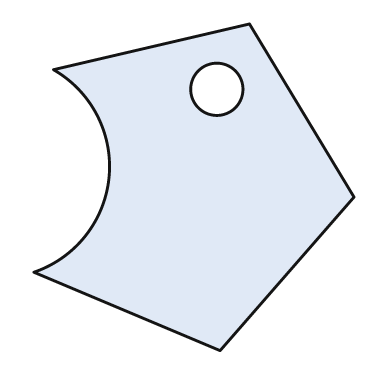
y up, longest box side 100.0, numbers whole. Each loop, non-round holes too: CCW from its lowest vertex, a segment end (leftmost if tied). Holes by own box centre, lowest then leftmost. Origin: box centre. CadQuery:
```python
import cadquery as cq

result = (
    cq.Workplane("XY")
    .moveTo(8.0, -50.0)
    .lineTo(49.0, -3.0)
    .lineTo(17.0, 50.0)
    .lineTo(-43.0, 36.0)
    .threePointArc((-26.0, 3.0), (-49.0, -26.0))
    .close()
    .moveTo(7.0, 30.0)
    .circle(8.0)
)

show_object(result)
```